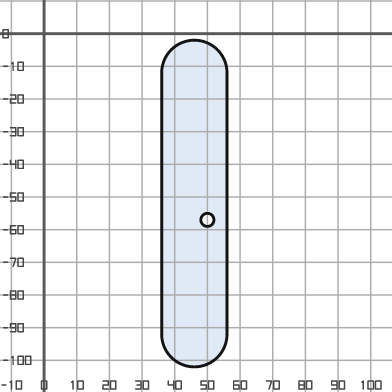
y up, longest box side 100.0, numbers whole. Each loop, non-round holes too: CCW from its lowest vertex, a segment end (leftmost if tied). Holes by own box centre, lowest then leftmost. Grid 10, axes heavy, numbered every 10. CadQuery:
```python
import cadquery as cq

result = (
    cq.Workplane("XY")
    .moveTo(36.0, -92.0)
    .threePointArc((46.0, -102.0), (56.0, -92.0))
    .lineTo(56.0, -12.0)
    .threePointArc((46.0, -2.0), (36.0, -12.0))
    .close()
    .moveTo(50.0, -57.0)
    .circle(2.0)
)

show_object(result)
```